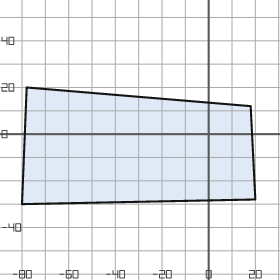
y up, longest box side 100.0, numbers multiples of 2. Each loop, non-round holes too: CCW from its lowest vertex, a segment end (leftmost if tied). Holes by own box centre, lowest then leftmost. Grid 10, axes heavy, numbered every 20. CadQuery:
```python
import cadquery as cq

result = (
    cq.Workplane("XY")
    .moveTo(-80.0, -30.0)
    .lineTo(20.0, -28.0)
    .lineTo(18.0, 12.0)
    .lineTo(-78.0, 20.0)
    .close()
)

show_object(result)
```